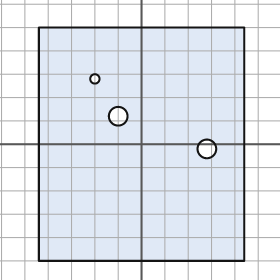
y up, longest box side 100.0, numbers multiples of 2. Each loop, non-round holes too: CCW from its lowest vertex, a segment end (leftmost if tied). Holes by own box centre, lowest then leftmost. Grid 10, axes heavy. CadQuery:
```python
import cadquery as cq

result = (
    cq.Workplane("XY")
    .moveTo(-44.0, -50.0)
    .lineTo(44.0, -50.0)
    .lineTo(44.0, 50.0)
    .lineTo(-44.0, 50.0)
    .close()
    .moveTo(28.0, -2.0)
    .circle(4.0)
    .moveTo(-10.0, 12.0)
    .circle(4.0)
    .moveTo(-20.0, 28.0)
    .circle(2.0)
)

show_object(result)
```